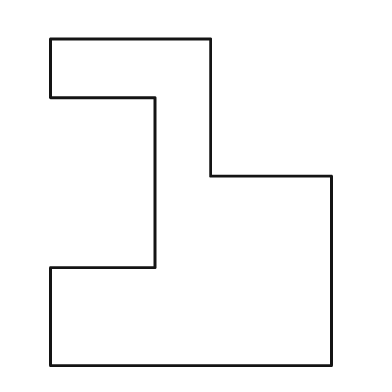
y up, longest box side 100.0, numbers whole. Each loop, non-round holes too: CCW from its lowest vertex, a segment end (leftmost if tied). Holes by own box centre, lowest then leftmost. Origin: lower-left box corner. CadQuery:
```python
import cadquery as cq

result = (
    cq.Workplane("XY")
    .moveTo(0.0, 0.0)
    .lineTo(86.0, 0.0)
    .lineTo(86.0, 58.0)
    .lineTo(49.0, 58.0)
    .lineTo(49.0, 100.0)
    .lineTo(0.0, 100.0)
    .lineTo(0.0, 82.0)
    .lineTo(32.0, 82.0)
    .lineTo(32.0, 30.0)
    .lineTo(0.0, 30.0)
    .close()
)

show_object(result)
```